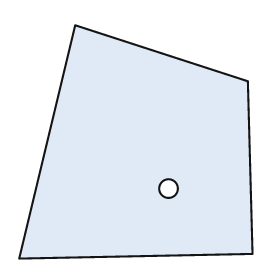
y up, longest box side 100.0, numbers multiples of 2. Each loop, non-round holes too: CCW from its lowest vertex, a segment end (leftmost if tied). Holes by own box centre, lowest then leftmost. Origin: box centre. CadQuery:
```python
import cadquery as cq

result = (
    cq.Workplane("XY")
    .moveTo(-50.0, -50.0)
    .lineTo(50.0, -48.0)
    .lineTo(48.0, 26.0)
    .lineTo(-26.0, 50.0)
    .close()
    .moveTo(14.0, -20.0)
    .circle(4.0)
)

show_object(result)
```